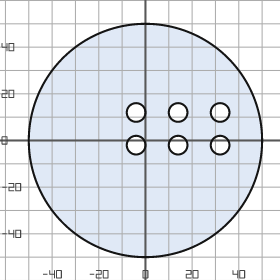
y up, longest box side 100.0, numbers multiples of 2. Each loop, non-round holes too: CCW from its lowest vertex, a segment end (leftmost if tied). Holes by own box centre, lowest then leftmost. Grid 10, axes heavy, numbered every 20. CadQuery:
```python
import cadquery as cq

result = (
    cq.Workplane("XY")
    .moveTo(0.0, 0.0)
    .circle(50.0)
    .moveTo(-4.0, -2.0)
    .circle(4.0)
    .moveTo(14.0, -2.0)
    .circle(4.0)
    .moveTo(32.0, -2.0)
    .circle(4.0)
    .moveTo(-4.0, 12.0)
    .circle(4.0)
    .moveTo(14.0, 12.0)
    .circle(4.0)
    .moveTo(32.0, 12.0)
    .circle(4.0)
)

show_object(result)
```